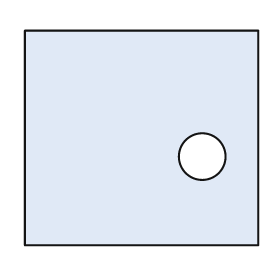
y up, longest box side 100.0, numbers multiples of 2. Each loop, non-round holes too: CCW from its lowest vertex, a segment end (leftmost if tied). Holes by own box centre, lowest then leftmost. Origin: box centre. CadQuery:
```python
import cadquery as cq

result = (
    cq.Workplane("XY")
    .moveTo(-50.0, -46.0)
    .lineTo(50.0, -46.0)
    .lineTo(50.0, 46.0)
    .lineTo(-50.0, 46.0)
    .close()
    .moveTo(26.0, -8.0)
    .circle(10.0)
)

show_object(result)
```